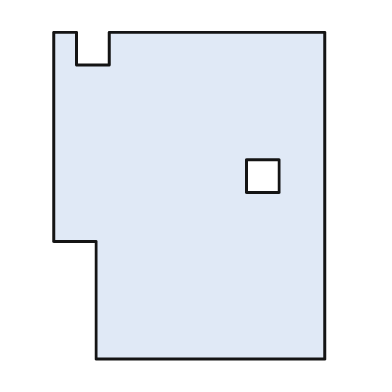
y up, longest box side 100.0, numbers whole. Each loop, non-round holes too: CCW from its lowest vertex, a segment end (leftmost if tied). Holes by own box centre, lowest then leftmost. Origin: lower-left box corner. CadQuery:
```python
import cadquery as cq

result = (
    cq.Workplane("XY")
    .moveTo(13.0, 0.0)
    .lineTo(83.0, 0.0)
    .lineTo(83.0, 100.0)
    .lineTo(17.0, 100.0)
    .lineTo(17.0, 90.0)
    .lineTo(7.0, 90.0)
    .lineTo(7.0, 100.0)
    .lineTo(0.0, 100.0)
    .lineTo(0.0, 36.0)
    .lineTo(13.0, 36.0)
    .close()
    .moveTo(59.0, 51.0)
    .lineTo(69.0, 51.0)
    .lineTo(69.0, 61.0)
    .lineTo(59.0, 61.0)
    .close()
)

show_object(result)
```